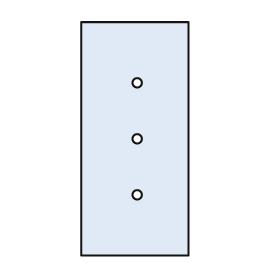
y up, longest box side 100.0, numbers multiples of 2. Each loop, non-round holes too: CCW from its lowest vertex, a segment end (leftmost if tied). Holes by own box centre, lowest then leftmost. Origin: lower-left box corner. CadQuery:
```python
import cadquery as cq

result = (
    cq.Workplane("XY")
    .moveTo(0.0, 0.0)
    .lineTo(46.0, 0.0)
    .lineTo(46.0, 100.0)
    .lineTo(0.0, 100.0)
    .close()
    .moveTo(24.0, 26.0)
    .circle(2.0)
    .moveTo(24.0, 50.0)
    .circle(2.0)
    .moveTo(24.0, 74.0)
    .circle(2.0)
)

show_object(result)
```